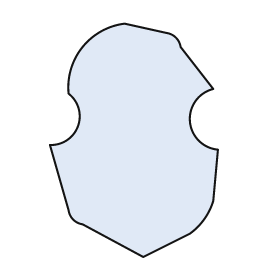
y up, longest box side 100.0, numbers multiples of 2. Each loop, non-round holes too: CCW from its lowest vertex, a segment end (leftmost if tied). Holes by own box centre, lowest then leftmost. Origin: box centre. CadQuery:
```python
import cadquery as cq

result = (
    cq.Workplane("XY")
    .moveTo(4.0, -50.0)
    .lineTo(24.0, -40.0)
    .threePointArc((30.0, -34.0), (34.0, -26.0))
    .lineTo(36.0, -4.0)
    .threePointArc((24.0, 8.0), (34.0, 22.0))
    .lineTo(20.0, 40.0)
    .threePointArc((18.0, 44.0), (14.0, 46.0))
    .lineTo(-4.0, 50.0)
    .threePointArc((-22.0, 40.0), (-28.0, 20.0))
    .threePointArc((-24.0, 6.0), (-36.0, -2.0))
    .lineTo(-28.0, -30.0)
    .threePointArc((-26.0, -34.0), (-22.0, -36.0))
    .close()
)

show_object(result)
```